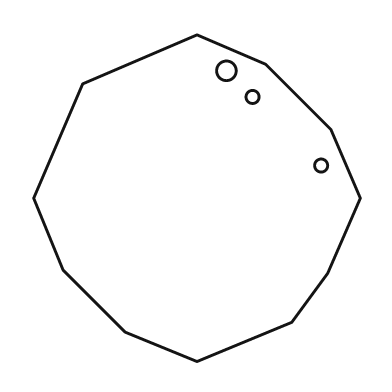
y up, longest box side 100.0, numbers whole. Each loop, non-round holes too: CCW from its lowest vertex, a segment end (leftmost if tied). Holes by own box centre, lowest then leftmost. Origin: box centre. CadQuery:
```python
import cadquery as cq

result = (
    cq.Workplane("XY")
    .moveTo(0.0, -50.0)
    .lineTo(29.0, -38.0)
    .lineTo(40.0, -23.0)
    .lineTo(50.0, 0.0)
    .lineTo(41.0, 21.0)
    .lineTo(21.0, 41.0)
    .lineTo(0.0, 50.0)
    .lineTo(-35.0, 35.0)
    .lineTo(-50.0, 0.0)
    .lineTo(-41.0, -22.0)
    .lineTo(-22.0, -41.0)
    .close()
    .moveTo(38.0, 10.0)
    .circle(2.0)
    .moveTo(17.0, 31.0)
    .circle(2.0)
    .moveTo(9.0, 39.0)
    .circle(3.0)
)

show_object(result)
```